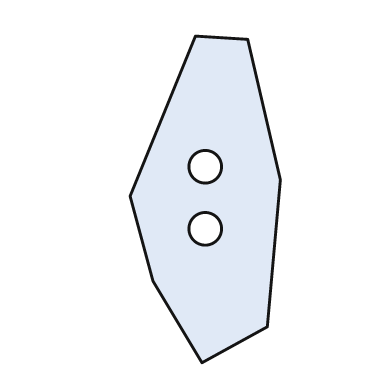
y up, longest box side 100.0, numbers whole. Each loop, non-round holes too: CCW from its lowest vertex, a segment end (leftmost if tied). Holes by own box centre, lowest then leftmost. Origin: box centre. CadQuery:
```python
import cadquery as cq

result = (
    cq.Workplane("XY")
    .moveTo(-1.0, -50.0)
    .lineTo(19.0, -39.0)
    .lineTo(23.0, 6.0)
    .lineTo(13.0, 49.0)
    .lineTo(-3.0, 50.0)
    .lineTo(-23.0, 1.0)
    .lineTo(-16.0, -25.0)
    .close()
    .moveTo(0.0, -9.0)
    .circle(5.0)
    .moveTo(0.0, 10.0)
    .circle(5.0)
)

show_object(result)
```